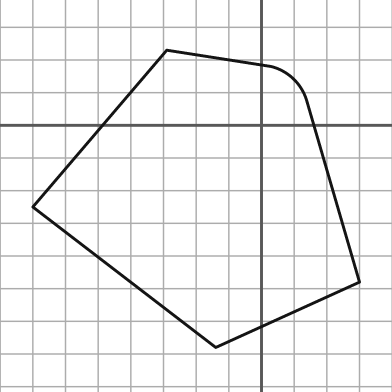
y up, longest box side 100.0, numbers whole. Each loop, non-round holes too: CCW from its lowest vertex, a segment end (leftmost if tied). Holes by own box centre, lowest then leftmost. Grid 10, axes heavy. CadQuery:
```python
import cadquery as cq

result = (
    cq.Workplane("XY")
    .moveTo(-14.0, -68.0)
    .lineTo(30.0, -48.0)
    .lineTo(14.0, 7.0)
    .threePointArc((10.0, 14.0), (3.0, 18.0))
    .lineTo(-29.0, 23.0)
    .lineTo(-70.0, -25.0)
    .close()
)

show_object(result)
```